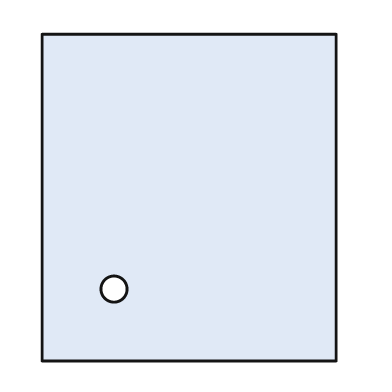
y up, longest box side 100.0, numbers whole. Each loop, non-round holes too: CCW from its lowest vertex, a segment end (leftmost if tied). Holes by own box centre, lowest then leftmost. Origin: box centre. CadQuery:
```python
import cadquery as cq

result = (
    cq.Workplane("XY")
    .moveTo(-45.0, -50.0)
    .lineTo(45.0, -50.0)
    .lineTo(45.0, 50.0)
    .lineTo(-45.0, 50.0)
    .close()
    .moveTo(-23.0, -28.0)
    .circle(4.0)
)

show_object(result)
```